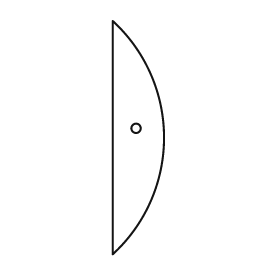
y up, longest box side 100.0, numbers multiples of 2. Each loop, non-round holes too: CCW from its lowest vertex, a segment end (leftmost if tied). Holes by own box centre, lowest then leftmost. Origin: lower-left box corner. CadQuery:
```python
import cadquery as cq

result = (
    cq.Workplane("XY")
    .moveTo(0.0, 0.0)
    .threePointArc((22.0, 50.0), (0.0, 100.0))
    .close()
    .moveTo(10.0, 54.0)
    .circle(2.0)
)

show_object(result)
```